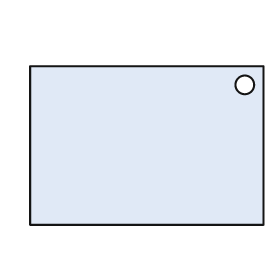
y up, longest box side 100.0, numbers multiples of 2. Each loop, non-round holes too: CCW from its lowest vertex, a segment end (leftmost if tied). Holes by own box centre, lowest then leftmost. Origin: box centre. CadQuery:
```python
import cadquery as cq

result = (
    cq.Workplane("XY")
    .moveTo(-50.0, -34.0)
    .lineTo(50.0, -34.0)
    .lineTo(50.0, 34.0)
    .lineTo(-50.0, 34.0)
    .close()
    .moveTo(42.0, 26.0)
    .circle(4.0)
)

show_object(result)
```